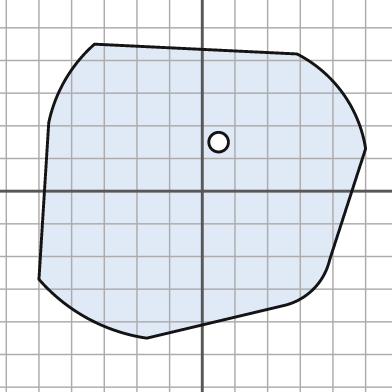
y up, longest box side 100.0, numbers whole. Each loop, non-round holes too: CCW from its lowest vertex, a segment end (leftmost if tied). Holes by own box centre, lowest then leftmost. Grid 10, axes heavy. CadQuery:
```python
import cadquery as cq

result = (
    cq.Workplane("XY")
    .moveTo(-17.0, -45.0)
    .lineTo(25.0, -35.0)
    .threePointArc((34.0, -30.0), (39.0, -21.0))
    .lineTo(50.0, 13.0)
    .threePointArc((43.0, 30.0), (29.0, 42.0))
    .lineTo(-33.0, 45.0)
    .threePointArc((-42.0, 34.0), (-47.0, 21.0))
    .lineTo(-50.0, -27.0)
    .threePointArc((-35.0, -39.0), (-17.0, -45.0))
    .close()
    .moveTo(5.0, 15.0)
    .circle(3.0)
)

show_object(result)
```